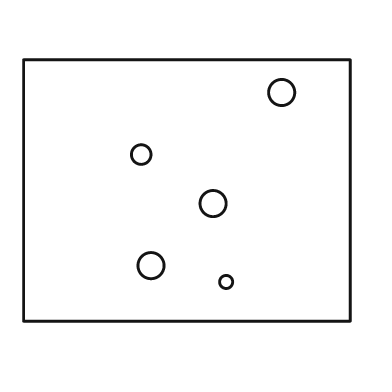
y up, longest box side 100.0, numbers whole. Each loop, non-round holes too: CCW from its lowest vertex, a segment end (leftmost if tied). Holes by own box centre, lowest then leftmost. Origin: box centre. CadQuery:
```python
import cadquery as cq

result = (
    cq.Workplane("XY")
    .moveTo(-50.0, -40.0)
    .lineTo(50.0, -40.0)
    .lineTo(50.0, 40.0)
    .lineTo(-50.0, 40.0)
    .close()
    .moveTo(12.0, -28.0)
    .circle(2.0)
    .moveTo(-11.0, -23.0)
    .circle(4.0)
    .moveTo(8.0, -4.0)
    .circle(4.0)
    .moveTo(-14.0, 11.0)
    .circle(3.0)
    .moveTo(29.0, 30.0)
    .circle(4.0)
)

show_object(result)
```